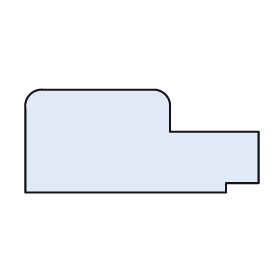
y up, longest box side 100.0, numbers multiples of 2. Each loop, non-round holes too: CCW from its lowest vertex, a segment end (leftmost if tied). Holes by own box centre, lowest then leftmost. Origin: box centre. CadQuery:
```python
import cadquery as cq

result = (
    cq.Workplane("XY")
    .moveTo(-50.0, -22.0)
    .lineTo(36.0, -22.0)
    .lineTo(36.0, -18.0)
    .lineTo(50.0, -18.0)
    .lineTo(50.0, 4.0)
    .lineTo(12.0, 4.0)
    .lineTo(12.0, 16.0)
    .threePointArc((10.0, 20.0), (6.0, 22.0))
    .lineTo(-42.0, 22.0)
    .threePointArc((-48.0, 20.0), (-50.0, 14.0))
    .close()
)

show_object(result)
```